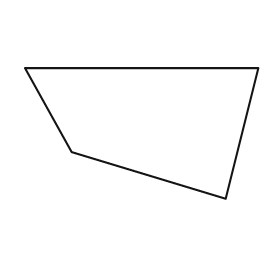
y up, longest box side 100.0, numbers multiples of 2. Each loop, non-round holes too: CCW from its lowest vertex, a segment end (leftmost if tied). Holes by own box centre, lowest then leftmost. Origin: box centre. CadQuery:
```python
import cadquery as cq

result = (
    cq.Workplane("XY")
    .moveTo(36.0, -28.0)
    .lineTo(50.0, 28.0)
    .lineTo(-50.0, 28.0)
    .lineTo(-30.0, -8.0)
    .close()
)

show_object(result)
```